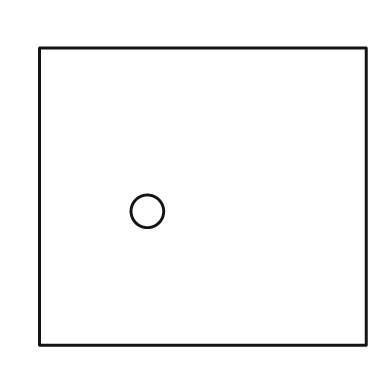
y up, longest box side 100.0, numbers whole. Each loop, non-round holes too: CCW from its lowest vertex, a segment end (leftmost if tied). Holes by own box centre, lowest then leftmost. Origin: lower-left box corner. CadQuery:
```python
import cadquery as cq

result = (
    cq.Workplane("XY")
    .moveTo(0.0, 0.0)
    .lineTo(100.0, 0.0)
    .lineTo(100.0, 91.0)
    .lineTo(0.0, 91.0)
    .close()
    .moveTo(33.0, 41.0)
    .circle(5.0)
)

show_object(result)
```